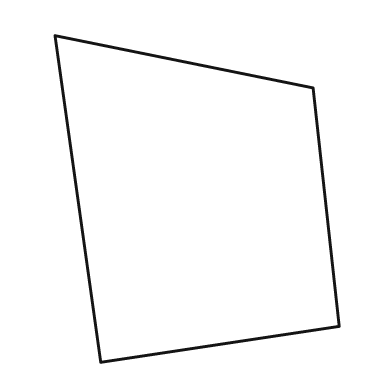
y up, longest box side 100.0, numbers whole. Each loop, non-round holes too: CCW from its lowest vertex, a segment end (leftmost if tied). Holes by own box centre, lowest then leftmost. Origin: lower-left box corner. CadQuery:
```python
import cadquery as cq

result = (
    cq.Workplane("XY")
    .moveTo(14.0, 0.0)
    .lineTo(87.0, 11.0)
    .lineTo(79.0, 84.0)
    .lineTo(0.0, 100.0)
    .close()
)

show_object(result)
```